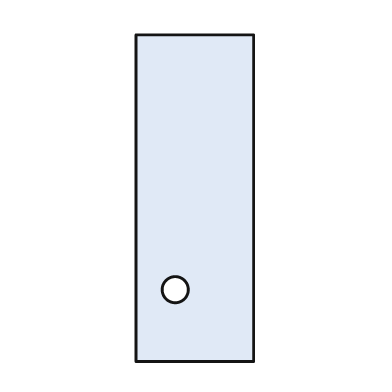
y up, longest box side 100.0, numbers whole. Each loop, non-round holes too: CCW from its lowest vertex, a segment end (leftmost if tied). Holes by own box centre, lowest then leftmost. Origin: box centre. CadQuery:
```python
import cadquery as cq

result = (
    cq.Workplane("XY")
    .moveTo(-18.0, -50.0)
    .lineTo(18.0, -50.0)
    .lineTo(18.0, 50.0)
    .lineTo(-18.0, 50.0)
    .close()
    .moveTo(-6.0, -28.0)
    .circle(4.0)
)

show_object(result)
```